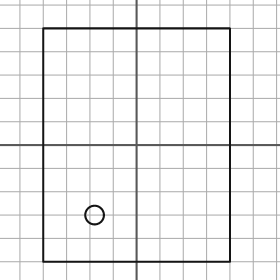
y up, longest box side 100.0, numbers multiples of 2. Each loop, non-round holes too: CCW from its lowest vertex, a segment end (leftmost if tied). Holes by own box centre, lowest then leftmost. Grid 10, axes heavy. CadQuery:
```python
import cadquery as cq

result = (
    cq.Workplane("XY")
    .moveTo(-40.0, -50.0)
    .lineTo(40.0, -50.0)
    .lineTo(40.0, 50.0)
    .lineTo(-40.0, 50.0)
    .close()
    .moveTo(-18.0, -30.0)
    .circle(4.0)
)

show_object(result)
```